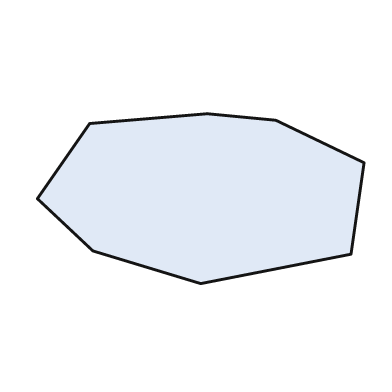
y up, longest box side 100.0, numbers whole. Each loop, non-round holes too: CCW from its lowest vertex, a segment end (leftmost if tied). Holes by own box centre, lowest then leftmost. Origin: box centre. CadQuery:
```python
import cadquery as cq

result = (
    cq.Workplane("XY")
    .moveTo(0.0, -26.0)
    .lineTo(46.0, -17.0)
    .lineTo(50.0, 11.0)
    .lineTo(23.0, 24.0)
    .lineTo(2.0, 26.0)
    .lineTo(-34.0, 23.0)
    .lineTo(-50.0, 0.0)
    .lineTo(-33.0, -16.0)
    .close()
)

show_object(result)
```